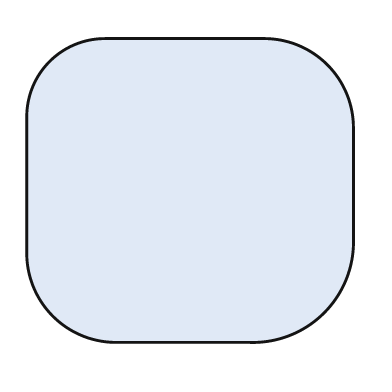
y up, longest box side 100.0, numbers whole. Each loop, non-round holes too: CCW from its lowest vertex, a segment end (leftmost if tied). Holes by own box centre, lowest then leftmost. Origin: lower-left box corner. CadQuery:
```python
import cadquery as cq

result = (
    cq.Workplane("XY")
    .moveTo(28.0, 0.0)
    .lineTo(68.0, 0.0)
    .threePointArc((91.0, 9.0), (100.0, 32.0))
    .lineTo(100.0, 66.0)
    .threePointArc((92.0, 85.0), (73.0, 93.0))
    .lineTo(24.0, 93.0)
    .threePointArc((7.0, 86.0), (0.0, 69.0))
    .lineTo(0.0, 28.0)
    .threePointArc((8.0, 8.0), (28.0, 0.0))
    .close()
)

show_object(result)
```